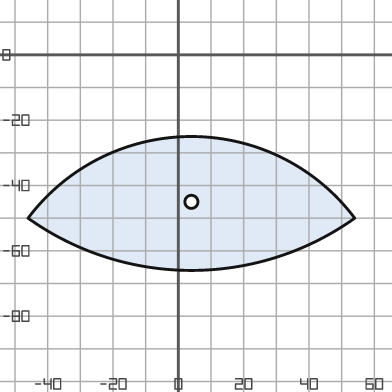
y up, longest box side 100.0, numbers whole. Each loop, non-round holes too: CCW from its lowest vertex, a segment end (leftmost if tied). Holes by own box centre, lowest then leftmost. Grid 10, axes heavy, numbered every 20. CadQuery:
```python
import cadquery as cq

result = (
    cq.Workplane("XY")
    .moveTo(-46.0, -50.0)
    .threePointArc((4.0, -66.0), (54.0, -50.0))
    .threePointArc((4.0, -25.0), (-46.0, -50.0))
    .close()
    .moveTo(4.0, -45.0)
    .circle(2.0)
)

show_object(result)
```